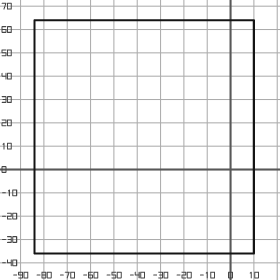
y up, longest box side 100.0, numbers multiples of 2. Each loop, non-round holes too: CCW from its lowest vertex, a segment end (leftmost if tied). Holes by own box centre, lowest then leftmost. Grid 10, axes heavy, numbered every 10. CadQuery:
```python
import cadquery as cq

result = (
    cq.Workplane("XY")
    .moveTo(-84.0, -36.0)
    .lineTo(10.0, -36.0)
    .lineTo(10.0, 64.0)
    .lineTo(-84.0, 64.0)
    .close()
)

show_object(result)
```